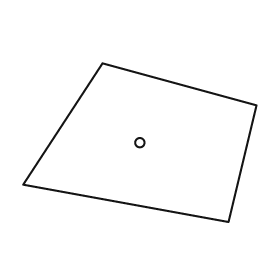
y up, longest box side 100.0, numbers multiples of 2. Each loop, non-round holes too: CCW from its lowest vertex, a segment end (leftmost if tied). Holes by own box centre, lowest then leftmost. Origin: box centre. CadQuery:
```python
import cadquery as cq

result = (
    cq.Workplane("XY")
    .moveTo(38.0, -34.0)
    .lineTo(50.0, 16.0)
    .lineTo(-16.0, 34.0)
    .lineTo(-50.0, -18.0)
    .close()
    .moveTo(0.0, 0.0)
    .circle(2.0)
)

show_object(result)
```